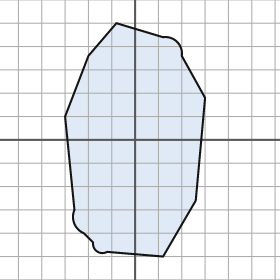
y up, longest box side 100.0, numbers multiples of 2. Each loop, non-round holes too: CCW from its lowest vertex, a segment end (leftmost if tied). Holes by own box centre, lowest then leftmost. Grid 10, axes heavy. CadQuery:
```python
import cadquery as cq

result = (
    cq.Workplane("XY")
    .moveTo(12.0, -50.0)
    .lineTo(26.0, -26.0)
    .lineTo(30.0, 18.0)
    .lineTo(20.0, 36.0)
    .threePointArc((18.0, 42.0), (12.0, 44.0))
    .lineTo(-8.0, 50.0)
    .lineTo(-20.0, 36.0)
    .lineTo(-30.0, 10.0)
    .lineTo(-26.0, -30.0)
    .threePointArc((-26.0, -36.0), (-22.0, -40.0))
    .lineTo(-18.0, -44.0)
    .threePointArc((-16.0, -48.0), (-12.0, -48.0))
    .close()
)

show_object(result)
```